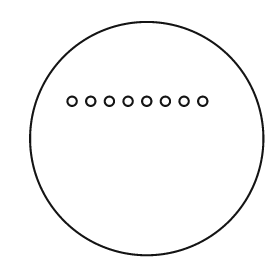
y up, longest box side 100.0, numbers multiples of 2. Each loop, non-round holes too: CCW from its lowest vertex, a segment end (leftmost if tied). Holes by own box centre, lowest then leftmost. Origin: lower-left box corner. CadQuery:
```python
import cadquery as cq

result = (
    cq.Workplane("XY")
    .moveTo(50.0, 50.0)
    .circle(50.0)
    .moveTo(18.0, 66.0)
    .circle(2.0)
    .moveTo(26.0, 66.0)
    .circle(2.0)
    .moveTo(34.0, 66.0)
    .circle(2.0)
    .moveTo(42.0, 66.0)
    .circle(2.0)
    .moveTo(50.0, 66.0)
    .circle(2.0)
    .moveTo(58.0, 66.0)
    .circle(2.0)
    .moveTo(66.0, 66.0)
    .circle(2.0)
    .moveTo(74.0, 66.0)
    .circle(2.0)
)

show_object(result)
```